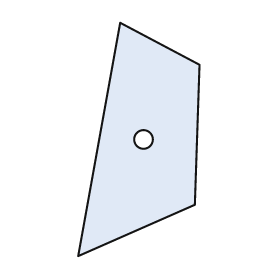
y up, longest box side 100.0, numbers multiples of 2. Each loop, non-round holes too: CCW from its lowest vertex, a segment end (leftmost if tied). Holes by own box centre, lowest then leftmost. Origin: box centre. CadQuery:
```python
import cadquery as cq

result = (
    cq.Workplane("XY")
    .moveTo(-26.0, -50.0)
    .lineTo(24.0, -28.0)
    .lineTo(26.0, 32.0)
    .lineTo(-8.0, 50.0)
    .close()
    .moveTo(2.0, 0.0)
    .circle(4.0)
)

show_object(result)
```